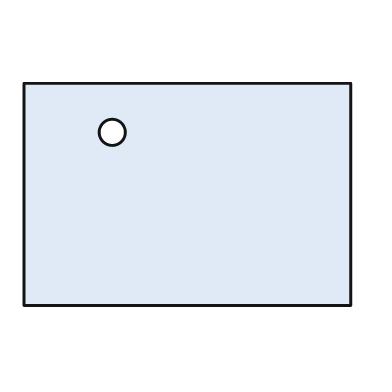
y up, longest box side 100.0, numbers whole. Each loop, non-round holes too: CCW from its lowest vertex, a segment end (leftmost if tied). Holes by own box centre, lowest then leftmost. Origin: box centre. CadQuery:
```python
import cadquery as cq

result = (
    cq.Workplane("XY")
    .moveTo(-50.0, -34.0)
    .lineTo(50.0, -34.0)
    .lineTo(50.0, 34.0)
    .lineTo(-50.0, 34.0)
    .close()
    .moveTo(-23.0, 19.0)
    .circle(4.0)
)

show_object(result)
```